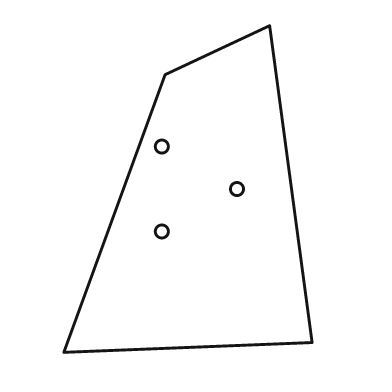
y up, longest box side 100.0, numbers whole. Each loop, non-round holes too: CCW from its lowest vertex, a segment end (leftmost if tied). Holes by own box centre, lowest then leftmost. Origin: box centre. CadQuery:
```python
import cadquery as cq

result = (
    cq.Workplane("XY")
    .moveTo(-38.0, -50.0)
    .lineTo(38.0, -47.0)
    .lineTo(25.0, 50.0)
    .lineTo(-7.0, 35.0)
    .close()
    .moveTo(-8.0, -13.0)
    .circle(2.0)
    .moveTo(15.0, 0.0)
    .circle(2.0)
    .moveTo(-8.0, 13.0)
    .circle(2.0)
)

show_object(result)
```